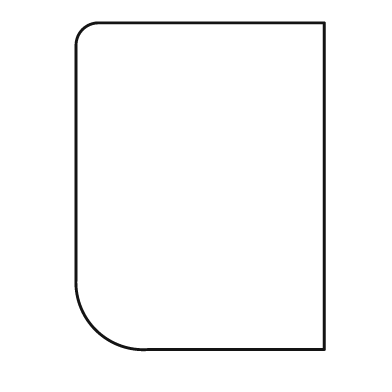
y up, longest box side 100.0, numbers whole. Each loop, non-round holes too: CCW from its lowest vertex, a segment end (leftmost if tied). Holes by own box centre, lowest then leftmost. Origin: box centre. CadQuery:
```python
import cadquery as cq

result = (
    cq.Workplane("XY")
    .moveTo(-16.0, -50.0)
    .lineTo(38.0, -50.0)
    .lineTo(38.0, 50.0)
    .lineTo(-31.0, 50.0)
    .threePointArc((-36.0, 48.0), (-38.0, 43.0))
    .lineTo(-38.0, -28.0)
    .threePointArc((-32.0, -44.0), (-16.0, -50.0))
    .close()
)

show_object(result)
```